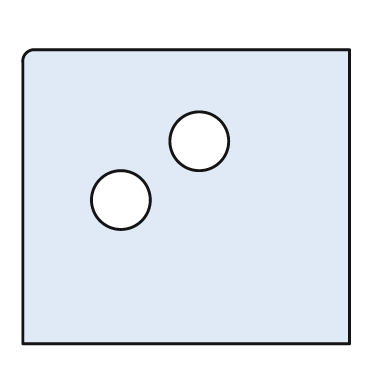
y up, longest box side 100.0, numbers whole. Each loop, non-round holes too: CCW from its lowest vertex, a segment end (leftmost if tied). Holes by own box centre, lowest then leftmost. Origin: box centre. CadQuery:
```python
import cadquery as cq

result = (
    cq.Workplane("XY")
    .moveTo(-50.0, -45.0)
    .lineTo(50.0, -45.0)
    .lineTo(50.0, 45.0)
    .lineTo(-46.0, 45.0)
    .threePointArc((-49.0, 44.0), (-50.0, 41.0))
    .close()
    .moveTo(-20.0, -1.0)
    .circle(9.0)
    .moveTo(4.0, 17.0)
    .circle(9.0)
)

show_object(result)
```